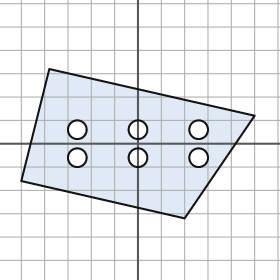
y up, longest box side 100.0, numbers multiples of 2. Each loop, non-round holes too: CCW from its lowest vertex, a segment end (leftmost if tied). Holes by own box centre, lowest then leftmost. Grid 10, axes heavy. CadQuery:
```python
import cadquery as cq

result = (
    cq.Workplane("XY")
    .moveTo(20.0, -32.0)
    .lineTo(50.0, 12.0)
    .lineTo(-38.0, 32.0)
    .lineTo(-50.0, -16.0)
    .close()
    .moveTo(-26.0, -6.0)
    .circle(4.0)
    .moveTo(0.0, -6.0)
    .circle(4.0)
    .moveTo(26.0, -6.0)
    .circle(4.0)
    .moveTo(-26.0, 6.0)
    .circle(4.0)
    .moveTo(0.0, 6.0)
    .circle(4.0)
    .moveTo(26.0, 6.0)
    .circle(4.0)
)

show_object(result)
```